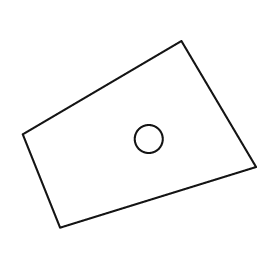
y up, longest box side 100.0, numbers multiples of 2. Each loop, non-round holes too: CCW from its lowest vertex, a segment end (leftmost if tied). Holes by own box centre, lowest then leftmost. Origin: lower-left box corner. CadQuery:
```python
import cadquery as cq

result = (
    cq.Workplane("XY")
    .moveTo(16.0, 0.0)
    .lineTo(100.0, 26.0)
    .lineTo(68.0, 80.0)
    .lineTo(0.0, 40.0)
    .close()
    .moveTo(54.0, 38.0)
    .circle(6.0)
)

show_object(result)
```